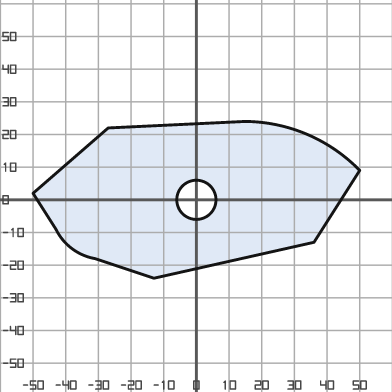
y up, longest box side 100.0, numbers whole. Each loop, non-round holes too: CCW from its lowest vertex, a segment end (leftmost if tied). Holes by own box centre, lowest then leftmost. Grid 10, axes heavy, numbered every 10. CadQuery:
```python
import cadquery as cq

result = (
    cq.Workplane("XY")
    .moveTo(-13.0, -24.0)
    .lineTo(36.0, -13.0)
    .lineTo(50.0, 9.0)
    .threePointArc((34.0, 20.0), (15.0, 24.0))
    .lineTo(-27.0, 22.0)
    .lineTo(-50.0, 2.0)
    .lineTo(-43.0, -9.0)
    .threePointArc((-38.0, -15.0), (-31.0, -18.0))
    .close()
    .moveTo(0.0, 0.0)
    .circle(6.0)
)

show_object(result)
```